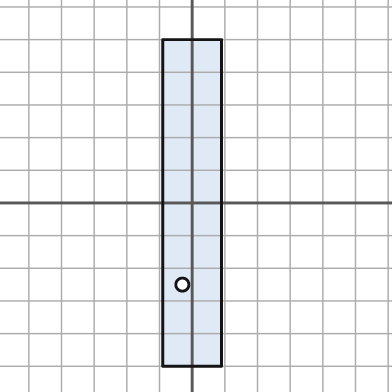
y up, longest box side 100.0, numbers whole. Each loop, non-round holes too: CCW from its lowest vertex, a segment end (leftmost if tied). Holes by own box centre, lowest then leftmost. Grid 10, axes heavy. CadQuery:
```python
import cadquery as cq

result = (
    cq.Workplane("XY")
    .moveTo(-9.0, -50.0)
    .lineTo(9.0, -50.0)
    .lineTo(9.0, 50.0)
    .lineTo(-9.0, 50.0)
    .close()
    .moveTo(-3.0, -25.0)
    .circle(2.0)
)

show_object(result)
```